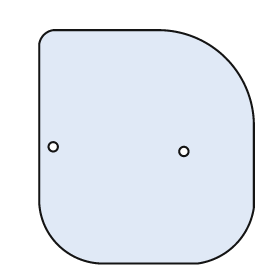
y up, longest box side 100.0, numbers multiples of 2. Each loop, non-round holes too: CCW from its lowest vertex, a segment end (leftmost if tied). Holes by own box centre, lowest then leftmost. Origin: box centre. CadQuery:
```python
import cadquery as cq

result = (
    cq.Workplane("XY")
    .moveTo(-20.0, -50.0)
    .lineTo(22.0, -50.0)
    .threePointArc((38.0, -42.0), (46.0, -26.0))
    .lineTo(46.0, 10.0)
    .threePointArc((34.0, 38.0), (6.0, 50.0))
    .lineTo(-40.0, 50.0)
    .threePointArc((-44.0, 48.0), (-46.0, 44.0))
    .lineTo(-46.0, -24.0)
    .threePointArc((-38.0, -42.0), (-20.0, -50.0))
    .close()
    .moveTo(16.0, -2.0)
    .circle(2.0)
    .moveTo(-40.0, 0.0)
    .circle(2.0)
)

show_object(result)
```